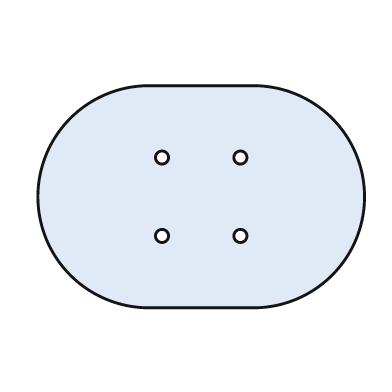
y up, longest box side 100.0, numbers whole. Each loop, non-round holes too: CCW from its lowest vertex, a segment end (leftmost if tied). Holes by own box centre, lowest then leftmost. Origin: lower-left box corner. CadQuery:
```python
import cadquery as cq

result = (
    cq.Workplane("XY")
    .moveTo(34.0, 0.0)
    .lineTo(66.0, 0.0)
    .threePointArc((100.0, 34.0), (66.0, 68.0))
    .lineTo(34.0, 68.0)
    .threePointArc((0.0, 34.0), (34.0, 0.0))
    .close()
    .moveTo(38.0, 22.0)
    .circle(2.0)
    .moveTo(62.0, 22.0)
    .circle(2.0)
    .moveTo(38.0, 46.0)
    .circle(2.0)
    .moveTo(62.0, 46.0)
    .circle(2.0)
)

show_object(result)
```